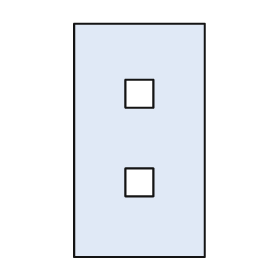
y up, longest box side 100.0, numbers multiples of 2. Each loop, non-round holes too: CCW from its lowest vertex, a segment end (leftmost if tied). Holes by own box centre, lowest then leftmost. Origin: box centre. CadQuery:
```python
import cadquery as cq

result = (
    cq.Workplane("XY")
    .moveTo(-28.0, -50.0)
    .lineTo(28.0, -50.0)
    .lineTo(28.0, 50.0)
    .lineTo(-28.0, 50.0)
    .close()
    .moveTo(-6.0, -24.0)
    .lineTo(6.0, -24.0)
    .lineTo(6.0, -12.0)
    .lineTo(-6.0, -12.0)
    .close()
    .moveTo(-6.0, 14.0)
    .lineTo(6.0, 14.0)
    .lineTo(6.0, 26.0)
    .lineTo(-6.0, 26.0)
    .close()
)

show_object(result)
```